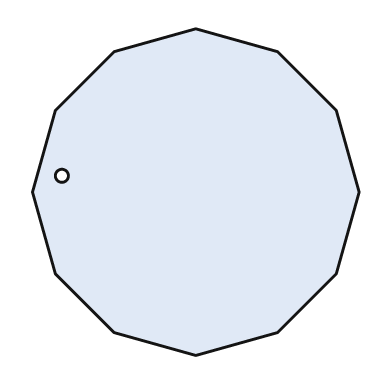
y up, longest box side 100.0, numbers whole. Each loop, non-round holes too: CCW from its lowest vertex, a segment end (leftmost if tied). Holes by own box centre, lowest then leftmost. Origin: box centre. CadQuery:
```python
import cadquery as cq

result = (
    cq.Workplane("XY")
    .moveTo(0.0, -50.0)
    .lineTo(25.0, -43.0)
    .lineTo(43.0, -25.0)
    .lineTo(50.0, 0.0)
    .lineTo(43.0, 25.0)
    .lineTo(25.0, 43.0)
    .lineTo(0.0, 50.0)
    .lineTo(-25.0, 43.0)
    .lineTo(-43.0, 25.0)
    .lineTo(-50.0, 0.0)
    .lineTo(-43.0, -25.0)
    .lineTo(-25.0, -43.0)
    .close()
    .moveTo(-41.0, 5.0)
    .circle(2.0)
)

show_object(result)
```